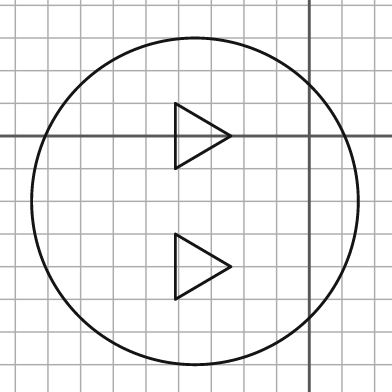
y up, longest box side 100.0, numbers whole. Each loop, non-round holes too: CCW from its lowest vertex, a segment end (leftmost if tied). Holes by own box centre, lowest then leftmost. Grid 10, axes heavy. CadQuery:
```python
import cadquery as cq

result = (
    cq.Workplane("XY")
    .moveTo(-35.0, -20.0)
    .circle(50.0)
    .moveTo(-41.0, -50.0)
    .lineTo(-24.0, -40.0)
    .lineTo(-41.0, -30.0)
    .close()
    .moveTo(-41.0, -10.0)
    .lineTo(-24.0, 0.0)
    .lineTo(-41.0, 10.0)
    .close()
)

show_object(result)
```